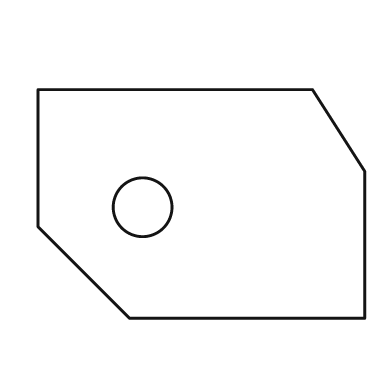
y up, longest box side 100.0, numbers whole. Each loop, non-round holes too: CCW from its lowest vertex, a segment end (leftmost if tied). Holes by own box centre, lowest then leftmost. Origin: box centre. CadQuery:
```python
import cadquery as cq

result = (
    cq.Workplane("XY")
    .moveTo(-22.0, -35.0)
    .lineTo(50.0, -35.0)
    .lineTo(50.0, 10.0)
    .lineTo(34.0, 35.0)
    .lineTo(-50.0, 35.0)
    .lineTo(-50.0, -7.0)
    .close()
    .moveTo(-18.0, -1.0)
    .circle(9.0)
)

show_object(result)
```